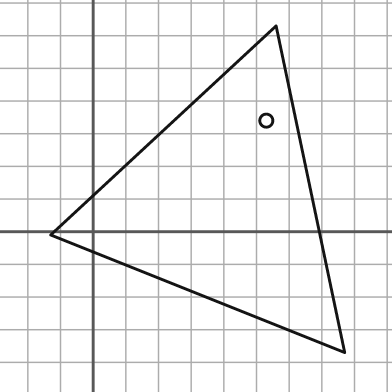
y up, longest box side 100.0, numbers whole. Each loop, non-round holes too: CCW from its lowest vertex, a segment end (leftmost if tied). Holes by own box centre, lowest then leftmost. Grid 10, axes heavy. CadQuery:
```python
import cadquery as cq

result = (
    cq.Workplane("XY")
    .moveTo(77.0, -37.0)
    .lineTo(56.0, 63.0)
    .lineTo(-13.0, -1.0)
    .close()
    .moveTo(53.0, 34.0)
    .circle(2.0)
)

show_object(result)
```